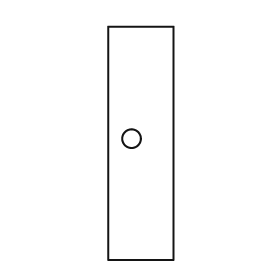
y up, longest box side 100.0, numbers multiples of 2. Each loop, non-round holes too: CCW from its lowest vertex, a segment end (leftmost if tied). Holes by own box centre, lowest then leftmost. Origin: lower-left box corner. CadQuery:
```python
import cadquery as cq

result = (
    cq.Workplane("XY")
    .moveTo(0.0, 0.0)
    .lineTo(28.0, 0.0)
    .lineTo(28.0, 100.0)
    .lineTo(0.0, 100.0)
    .close()
    .moveTo(10.0, 52.0)
    .circle(4.0)
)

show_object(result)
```